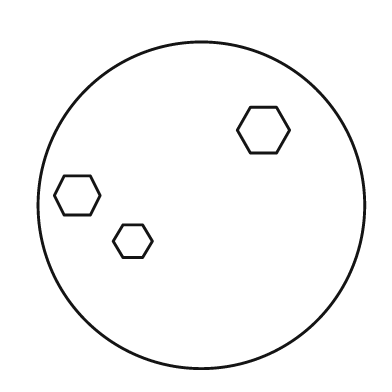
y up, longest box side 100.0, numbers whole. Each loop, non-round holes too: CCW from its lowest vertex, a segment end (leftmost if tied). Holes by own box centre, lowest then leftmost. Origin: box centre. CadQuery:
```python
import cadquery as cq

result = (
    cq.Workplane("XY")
    .moveTo(0.0, 0.0)
    .circle(50.0)
    .moveTo(-24.0, -16.0)
    .lineTo(-18.0, -16.0)
    .lineTo(-15.0, -11.0)
    .lineTo(-18.0, -6.0)
    .lineTo(-24.0, -6.0)
    .lineTo(-27.0, -11.0)
    .close()
    .moveTo(-42.0, -3.0)
    .lineTo(-34.0, -3.0)
    .lineTo(-31.0, 3.0)
    .lineTo(-34.0, 9.0)
    .lineTo(-42.0, 9.0)
    .lineTo(-45.0, 3.0)
    .close()
    .moveTo(15.0, 16.0)
    .lineTo(23.0, 16.0)
    .lineTo(27.0, 23.0)
    .lineTo(23.0, 30.0)
    .lineTo(15.0, 30.0)
    .lineTo(11.0, 23.0)
    .close()
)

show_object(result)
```